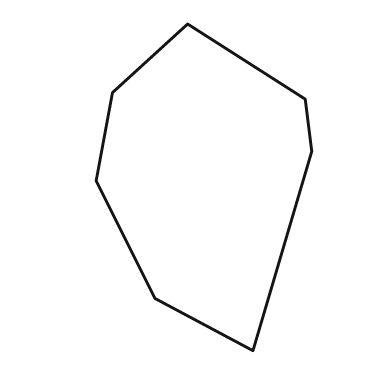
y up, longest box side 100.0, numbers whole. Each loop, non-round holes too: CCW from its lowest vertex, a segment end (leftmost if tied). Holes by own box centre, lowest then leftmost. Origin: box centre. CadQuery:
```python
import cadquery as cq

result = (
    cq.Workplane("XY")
    .moveTo(15.0, -50.0)
    .lineTo(33.0, 11.0)
    .lineTo(31.0, 27.0)
    .lineTo(-5.0, 50.0)
    .lineTo(-28.0, 29.0)
    .lineTo(-33.0, 2.0)
    .lineTo(-15.0, -34.0)
    .close()
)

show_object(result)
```